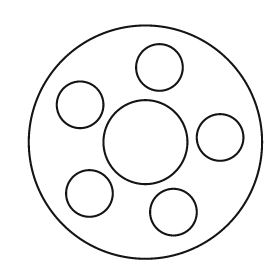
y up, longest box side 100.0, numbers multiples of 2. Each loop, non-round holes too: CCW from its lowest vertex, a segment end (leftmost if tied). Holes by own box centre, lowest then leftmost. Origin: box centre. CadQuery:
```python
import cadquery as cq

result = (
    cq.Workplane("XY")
    .moveTo(0.0, 0.0)
    .circle(50.0)
    .moveTo(12.0, -30.0)
    .circle(10.0)
    .moveTo(-24.0, -22.0)
    .circle(10.0)
    .moveTo(0.0, 0.0)
    .circle(18.0)
    .moveTo(32.0, 2.0)
    .circle(10.0)
    .moveTo(-28.0, 16.0)
    .circle(10.0)
    .moveTo(6.0, 32.0)
    .circle(10.0)
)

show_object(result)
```